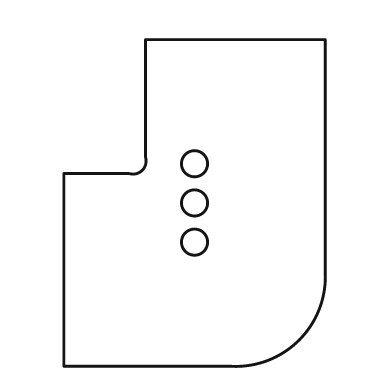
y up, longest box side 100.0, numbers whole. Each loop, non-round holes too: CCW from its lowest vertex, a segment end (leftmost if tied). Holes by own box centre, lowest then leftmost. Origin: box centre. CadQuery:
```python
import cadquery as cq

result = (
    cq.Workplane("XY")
    .moveTo(-40.0, -50.0)
    .lineTo(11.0, -50.0)
    .threePointArc((32.0, -42.0), (40.0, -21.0))
    .lineTo(40.0, 50.0)
    .lineTo(-15.0, 50.0)
    .lineTo(-15.0, 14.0)
    .threePointArc((-16.0, 10.0), (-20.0, 9.0))
    .lineTo(-40.0, 9.0)
    .close()
    .moveTo(0.0, -12.0)
    .circle(4.0)
    .moveTo(0.0, 0.0)
    .circle(4.0)
    .moveTo(0.0, 12.0)
    .circle(4.0)
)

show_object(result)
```